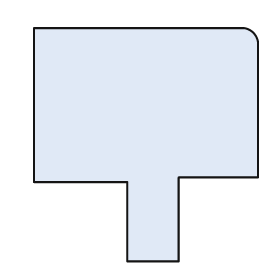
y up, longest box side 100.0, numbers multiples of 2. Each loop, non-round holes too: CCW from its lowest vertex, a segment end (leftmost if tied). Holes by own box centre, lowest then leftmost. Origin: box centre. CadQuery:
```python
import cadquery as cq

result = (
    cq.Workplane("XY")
    .moveTo(-8.0, -50.0)
    .lineTo(14.0, -50.0)
    .lineTo(14.0, -14.0)
    .lineTo(48.0, -14.0)
    .lineTo(48.0, 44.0)
    .threePointArc((46.0, 48.0), (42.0, 50.0))
    .lineTo(-48.0, 50.0)
    .lineTo(-48.0, -16.0)
    .lineTo(-8.0, -16.0)
    .close()
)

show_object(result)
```